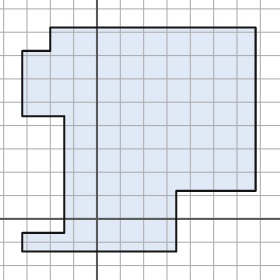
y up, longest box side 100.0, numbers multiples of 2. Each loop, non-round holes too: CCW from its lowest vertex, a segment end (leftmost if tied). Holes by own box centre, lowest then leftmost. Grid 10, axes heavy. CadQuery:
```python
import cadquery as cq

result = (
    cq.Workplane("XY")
    .moveTo(-32.0, -14.0)
    .lineTo(34.0, -14.0)
    .lineTo(34.0, 12.0)
    .lineTo(68.0, 12.0)
    .lineTo(68.0, 82.0)
    .lineTo(-20.0, 82.0)
    .lineTo(-20.0, 72.0)
    .lineTo(-32.0, 72.0)
    .lineTo(-32.0, 44.0)
    .lineTo(-14.0, 44.0)
    .lineTo(-14.0, -6.0)
    .lineTo(-32.0, -6.0)
    .close()
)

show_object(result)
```